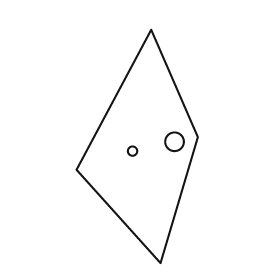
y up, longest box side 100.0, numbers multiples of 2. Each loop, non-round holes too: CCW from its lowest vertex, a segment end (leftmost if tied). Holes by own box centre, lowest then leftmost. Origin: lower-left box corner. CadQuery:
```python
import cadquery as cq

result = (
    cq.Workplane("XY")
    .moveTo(36.0, 0.0)
    .lineTo(52.0, 54.0)
    .lineTo(32.0, 100.0)
    .lineTo(0.0, 40.0)
    .close()
    .moveTo(24.0, 48.0)
    .circle(2.0)
    .moveTo(42.0, 52.0)
    .circle(4.0)
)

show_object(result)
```